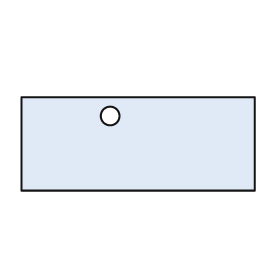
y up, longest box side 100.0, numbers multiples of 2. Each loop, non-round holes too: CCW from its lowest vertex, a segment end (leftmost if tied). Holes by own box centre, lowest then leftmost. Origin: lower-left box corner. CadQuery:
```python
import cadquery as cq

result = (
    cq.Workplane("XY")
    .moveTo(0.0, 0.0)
    .lineTo(100.0, 0.0)
    .lineTo(100.0, 40.0)
    .lineTo(0.0, 40.0)
    .close()
    .moveTo(38.0, 32.0)
    .circle(4.0)
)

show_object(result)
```